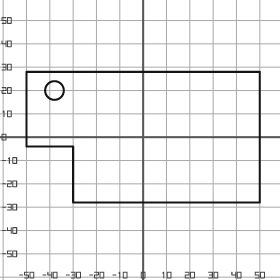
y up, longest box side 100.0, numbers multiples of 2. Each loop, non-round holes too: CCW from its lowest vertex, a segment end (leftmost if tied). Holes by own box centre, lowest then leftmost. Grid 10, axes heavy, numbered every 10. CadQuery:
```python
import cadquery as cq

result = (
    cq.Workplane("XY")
    .moveTo(-30.0, -28.0)
    .lineTo(50.0, -28.0)
    .lineTo(50.0, 28.0)
    .lineTo(-50.0, 28.0)
    .lineTo(-50.0, -4.0)
    .lineTo(-30.0, -4.0)
    .close()
    .moveTo(-38.0, 20.0)
    .circle(4.0)
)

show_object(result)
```